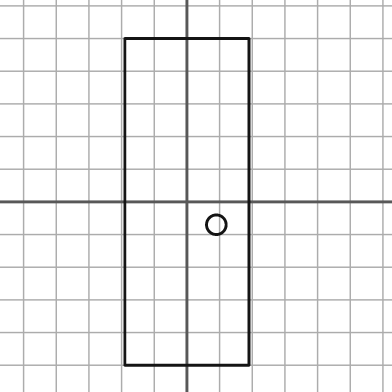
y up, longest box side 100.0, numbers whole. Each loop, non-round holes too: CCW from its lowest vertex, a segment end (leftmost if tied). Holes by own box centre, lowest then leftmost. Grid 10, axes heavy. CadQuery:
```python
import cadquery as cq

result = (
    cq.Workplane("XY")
    .moveTo(-19.0, -50.0)
    .lineTo(19.0, -50.0)
    .lineTo(19.0, 50.0)
    .lineTo(-19.0, 50.0)
    .close()
    .moveTo(9.0, -7.0)
    .circle(3.0)
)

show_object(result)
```